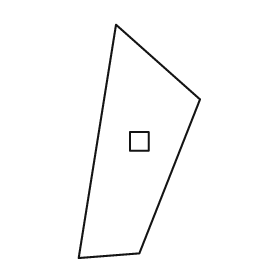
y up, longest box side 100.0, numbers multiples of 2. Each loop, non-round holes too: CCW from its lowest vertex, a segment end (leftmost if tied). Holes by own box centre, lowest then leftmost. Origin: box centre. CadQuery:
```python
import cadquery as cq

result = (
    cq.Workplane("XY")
    .moveTo(-26.0, -50.0)
    .lineTo(0.0, -48.0)
    .lineTo(26.0, 18.0)
    .lineTo(-10.0, 50.0)
    .close()
    .moveTo(-4.0, -4.0)
    .lineTo(4.0, -4.0)
    .lineTo(4.0, 4.0)
    .lineTo(-4.0, 4.0)
    .close()
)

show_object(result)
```